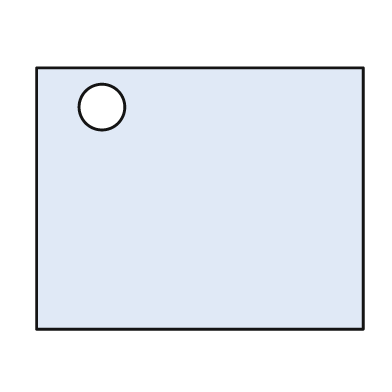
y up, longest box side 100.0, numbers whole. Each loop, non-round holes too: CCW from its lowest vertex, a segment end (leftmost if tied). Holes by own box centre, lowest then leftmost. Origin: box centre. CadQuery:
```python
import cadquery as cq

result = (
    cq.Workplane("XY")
    .moveTo(-50.0, -40.0)
    .lineTo(50.0, -40.0)
    .lineTo(50.0, 40.0)
    .lineTo(-50.0, 40.0)
    .close()
    .moveTo(-30.0, 28.0)
    .circle(7.0)
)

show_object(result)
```